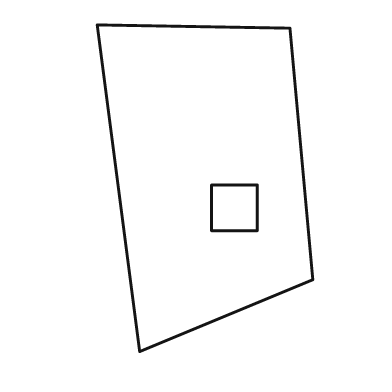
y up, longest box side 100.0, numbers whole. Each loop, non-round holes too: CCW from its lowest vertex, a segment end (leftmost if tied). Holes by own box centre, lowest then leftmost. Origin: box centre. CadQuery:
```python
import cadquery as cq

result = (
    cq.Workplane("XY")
    .moveTo(-20.0, -50.0)
    .lineTo(33.0, -28.0)
    .lineTo(26.0, 49.0)
    .lineTo(-33.0, 50.0)
    .close()
    .moveTo(2.0, -13.0)
    .lineTo(16.0, -13.0)
    .lineTo(16.0, 1.0)
    .lineTo(2.0, 1.0)
    .close()
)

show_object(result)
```